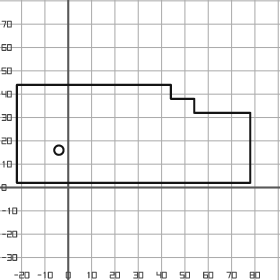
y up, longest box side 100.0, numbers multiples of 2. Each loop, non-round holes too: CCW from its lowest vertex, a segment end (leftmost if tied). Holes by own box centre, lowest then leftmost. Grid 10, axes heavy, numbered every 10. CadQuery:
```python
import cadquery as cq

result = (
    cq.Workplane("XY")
    .moveTo(-22.0, 2.0)
    .lineTo(78.0, 2.0)
    .lineTo(78.0, 32.0)
    .lineTo(54.0, 32.0)
    .lineTo(54.0, 38.0)
    .lineTo(44.0, 38.0)
    .lineTo(44.0, 44.0)
    .lineTo(-22.0, 44.0)
    .close()
    .moveTo(-4.0, 16.0)
    .circle(2.0)
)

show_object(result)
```